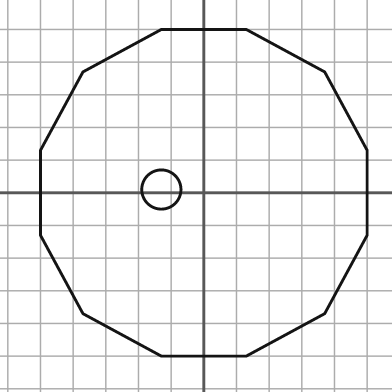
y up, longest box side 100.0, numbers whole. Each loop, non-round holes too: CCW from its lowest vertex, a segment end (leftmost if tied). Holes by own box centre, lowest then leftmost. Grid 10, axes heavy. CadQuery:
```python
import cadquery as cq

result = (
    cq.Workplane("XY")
    .moveTo(-13.0, -50.0)
    .lineTo(13.0, -50.0)
    .lineTo(37.0, -37.0)
    .lineTo(50.0, -13.0)
    .lineTo(50.0, 13.0)
    .lineTo(37.0, 37.0)
    .lineTo(13.0, 50.0)
    .lineTo(-13.0, 50.0)
    .lineTo(-37.0, 37.0)
    .lineTo(-50.0, 13.0)
    .lineTo(-50.0, -13.0)
    .lineTo(-37.0, -37.0)
    .close()
    .moveTo(-13.0, 1.0)
    .circle(6.0)
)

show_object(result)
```